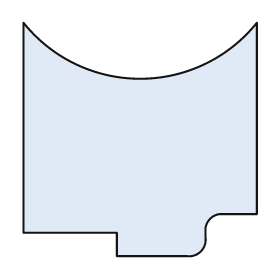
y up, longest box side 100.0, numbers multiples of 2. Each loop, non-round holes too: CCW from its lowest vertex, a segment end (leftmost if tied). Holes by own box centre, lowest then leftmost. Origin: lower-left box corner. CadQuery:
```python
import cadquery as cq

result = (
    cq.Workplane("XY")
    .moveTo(40.0, 0.0)
    .lineTo(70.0, 0.0)
    .threePointArc((76.0, 2.0), (78.0, 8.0))
    .lineTo(78.0, 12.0)
    .threePointArc((80.0, 16.0), (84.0, 18.0))
    .lineTo(100.0, 18.0)
    .lineTo(100.0, 100.0)
    .threePointArc((50.0, 76.0), (0.0, 100.0))
    .lineTo(0.0, 10.0)
    .lineTo(40.0, 10.0)
    .close()
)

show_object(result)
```